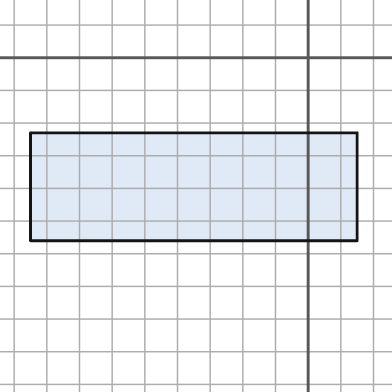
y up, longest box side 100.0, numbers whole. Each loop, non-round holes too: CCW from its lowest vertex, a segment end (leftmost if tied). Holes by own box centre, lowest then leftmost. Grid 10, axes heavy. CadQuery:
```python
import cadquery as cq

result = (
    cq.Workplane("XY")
    .moveTo(-85.0, -56.0)
    .lineTo(15.0, -56.0)
    .lineTo(15.0, -23.0)
    .lineTo(-85.0, -23.0)
    .close()
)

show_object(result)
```